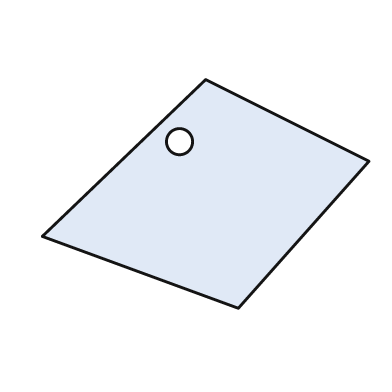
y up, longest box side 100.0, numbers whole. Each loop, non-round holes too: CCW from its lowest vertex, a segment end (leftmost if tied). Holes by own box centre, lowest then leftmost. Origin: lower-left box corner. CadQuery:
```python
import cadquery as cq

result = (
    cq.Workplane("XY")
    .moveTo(60.0, 0.0)
    .lineTo(100.0, 45.0)
    .lineTo(50.0, 70.0)
    .lineTo(0.0, 22.0)
    .close()
    .moveTo(42.0, 51.0)
    .circle(4.0)
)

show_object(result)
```